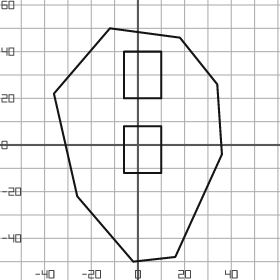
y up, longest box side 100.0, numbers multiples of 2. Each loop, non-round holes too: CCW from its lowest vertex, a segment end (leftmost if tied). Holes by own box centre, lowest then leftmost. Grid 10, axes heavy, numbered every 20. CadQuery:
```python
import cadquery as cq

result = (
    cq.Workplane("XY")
    .moveTo(-2.0, -50.0)
    .lineTo(16.0, -48.0)
    .lineTo(36.0, -4.0)
    .lineTo(34.0, 26.0)
    .lineTo(18.0, 46.0)
    .lineTo(-12.0, 50.0)
    .lineTo(-36.0, 22.0)
    .lineTo(-26.0, -22.0)
    .close()
    .moveTo(-6.0, -12.0)
    .lineTo(10.0, -12.0)
    .lineTo(10.0, 8.0)
    .lineTo(-6.0, 8.0)
    .close()
    .moveTo(-6.0, 20.0)
    .lineTo(10.0, 20.0)
    .lineTo(10.0, 40.0)
    .lineTo(-6.0, 40.0)
    .close()
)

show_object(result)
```